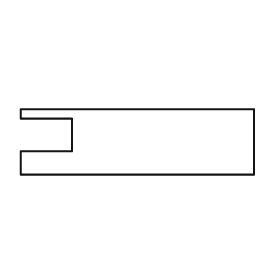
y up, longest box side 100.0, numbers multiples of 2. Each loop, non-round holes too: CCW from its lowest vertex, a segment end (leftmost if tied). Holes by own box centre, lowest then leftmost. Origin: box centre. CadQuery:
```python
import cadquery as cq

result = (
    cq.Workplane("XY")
    .moveTo(-50.0, -14.0)
    .lineTo(50.0, -14.0)
    .lineTo(50.0, 14.0)
    .lineTo(-50.0, 14.0)
    .lineTo(-50.0, 10.0)
    .lineTo(-28.0, 10.0)
    .lineTo(-28.0, -4.0)
    .lineTo(-50.0, -4.0)
    .close()
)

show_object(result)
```